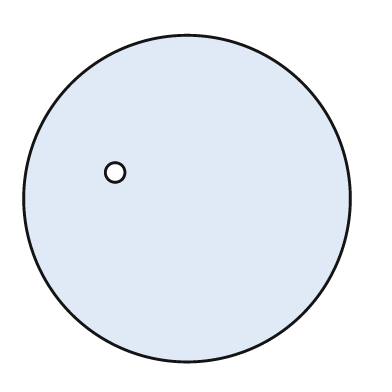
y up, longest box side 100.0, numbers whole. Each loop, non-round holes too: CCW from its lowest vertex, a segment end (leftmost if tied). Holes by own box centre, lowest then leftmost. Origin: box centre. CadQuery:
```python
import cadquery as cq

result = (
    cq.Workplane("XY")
    .moveTo(0.0, 0.0)
    .circle(50.0)
    .moveTo(-22.0, 8.0)
    .circle(3.0)
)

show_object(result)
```